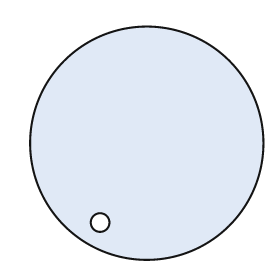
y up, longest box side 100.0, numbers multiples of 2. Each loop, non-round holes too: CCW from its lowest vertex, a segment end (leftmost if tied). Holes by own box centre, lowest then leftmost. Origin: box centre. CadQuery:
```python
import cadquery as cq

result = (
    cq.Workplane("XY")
    .moveTo(0.0, 0.0)
    .circle(50.0)
    .moveTo(-20.0, -34.0)
    .circle(4.0)
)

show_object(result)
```